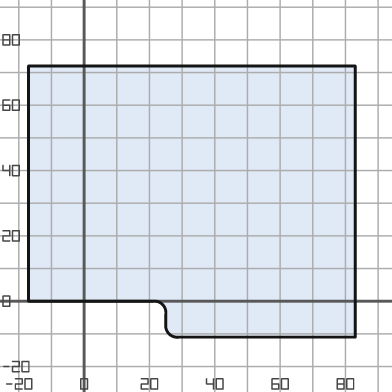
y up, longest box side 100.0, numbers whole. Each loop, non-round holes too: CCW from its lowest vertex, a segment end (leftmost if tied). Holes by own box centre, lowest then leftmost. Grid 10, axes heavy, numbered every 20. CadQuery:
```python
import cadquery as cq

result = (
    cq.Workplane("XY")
    .moveTo(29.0, -11.0)
    .lineTo(83.0, -11.0)
    .lineTo(83.0, 72.0)
    .lineTo(-17.0, 72.0)
    .lineTo(-17.0, 0.0)
    .lineTo(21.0, 0.0)
    .threePointArc((24.0, -1.0), (25.0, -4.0))
    .lineTo(25.0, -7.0)
    .threePointArc((26.0, -10.0), (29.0, -11.0))
    .close()
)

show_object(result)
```